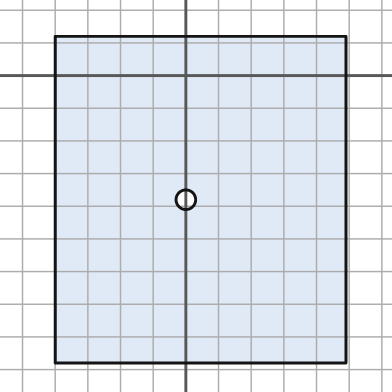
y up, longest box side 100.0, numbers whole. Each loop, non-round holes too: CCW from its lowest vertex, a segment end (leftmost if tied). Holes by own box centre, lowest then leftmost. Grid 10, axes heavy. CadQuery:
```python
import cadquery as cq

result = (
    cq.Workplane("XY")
    .moveTo(-40.0, -88.0)
    .lineTo(49.0, -88.0)
    .lineTo(49.0, 12.0)
    .lineTo(-40.0, 12.0)
    .close()
    .moveTo(0.0, -38.0)
    .circle(3.0)
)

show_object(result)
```